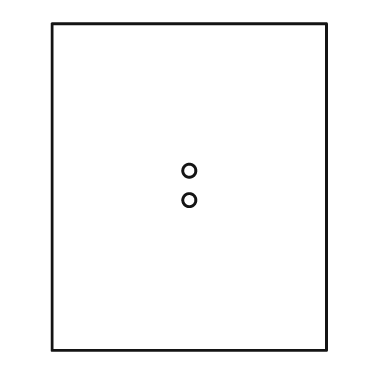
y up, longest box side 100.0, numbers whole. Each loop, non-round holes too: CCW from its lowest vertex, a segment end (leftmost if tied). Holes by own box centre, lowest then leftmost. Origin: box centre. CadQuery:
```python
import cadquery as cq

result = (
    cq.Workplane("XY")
    .moveTo(-42.0, -50.0)
    .lineTo(42.0, -50.0)
    .lineTo(42.0, 50.0)
    .lineTo(-42.0, 50.0)
    .close()
    .moveTo(0.0, -4.0)
    .circle(2.0)
    .moveTo(0.0, 5.0)
    .circle(2.0)
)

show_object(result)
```